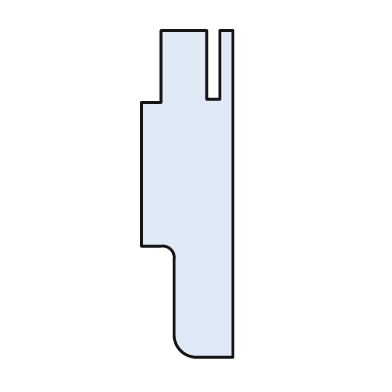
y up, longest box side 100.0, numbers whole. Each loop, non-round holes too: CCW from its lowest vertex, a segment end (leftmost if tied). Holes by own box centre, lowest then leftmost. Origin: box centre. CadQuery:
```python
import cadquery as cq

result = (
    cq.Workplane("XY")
    .moveTo(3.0, -50.0)
    .lineTo(14.0, -50.0)
    .lineTo(14.0, 50.0)
    .lineTo(10.0, 50.0)
    .lineTo(10.0, 29.0)
    .lineTo(6.0, 29.0)
    .lineTo(6.0, 50.0)
    .lineTo(-8.0, 50.0)
    .lineTo(-8.0, 28.0)
    .lineTo(-14.0, 28.0)
    .lineTo(-14.0, -16.0)
    .lineTo(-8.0, -16.0)
    .threePointArc((-5.0, -17.0), (-4.0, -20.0))
    .lineTo(-4.0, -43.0)
    .threePointArc((-2.0, -48.0), (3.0, -50.0))
    .close()
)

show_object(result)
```